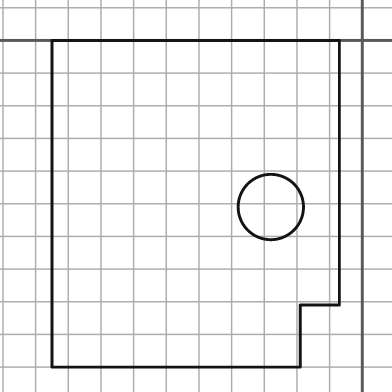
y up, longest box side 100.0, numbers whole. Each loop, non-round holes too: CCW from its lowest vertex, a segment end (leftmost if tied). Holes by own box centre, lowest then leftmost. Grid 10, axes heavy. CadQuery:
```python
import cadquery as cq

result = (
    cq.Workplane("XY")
    .moveTo(-95.0, -100.0)
    .lineTo(-19.0, -100.0)
    .lineTo(-19.0, -81.0)
    .lineTo(-7.0, -81.0)
    .lineTo(-7.0, 0.0)
    .lineTo(-95.0, 0.0)
    .close()
    .moveTo(-28.0, -51.0)
    .circle(10.0)
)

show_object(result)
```